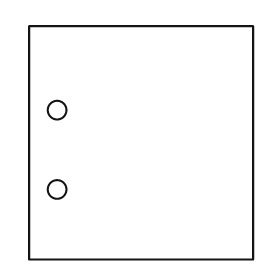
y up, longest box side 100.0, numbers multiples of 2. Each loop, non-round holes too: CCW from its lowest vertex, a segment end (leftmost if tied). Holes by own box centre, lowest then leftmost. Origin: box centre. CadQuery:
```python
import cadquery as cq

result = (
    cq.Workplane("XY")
    .moveTo(-48.0, -50.0)
    .lineTo(48.0, -50.0)
    .lineTo(48.0, 50.0)
    .lineTo(-48.0, 50.0)
    .close()
    .moveTo(-36.0, -20.0)
    .circle(4.0)
    .moveTo(-36.0, 14.0)
    .circle(4.0)
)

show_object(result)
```